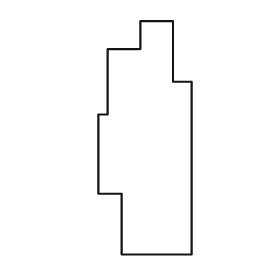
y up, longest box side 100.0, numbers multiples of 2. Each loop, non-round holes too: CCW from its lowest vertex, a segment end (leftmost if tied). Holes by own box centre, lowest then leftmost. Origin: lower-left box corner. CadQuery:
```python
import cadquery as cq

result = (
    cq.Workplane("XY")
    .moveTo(10.0, 0.0)
    .lineTo(40.0, 0.0)
    .lineTo(40.0, 74.0)
    .lineTo(32.0, 74.0)
    .lineTo(32.0, 100.0)
    .lineTo(18.0, 100.0)
    .lineTo(18.0, 88.0)
    .lineTo(4.0, 88.0)
    .lineTo(4.0, 60.0)
    .lineTo(0.0, 60.0)
    .lineTo(0.0, 26.0)
    .lineTo(10.0, 26.0)
    .close()
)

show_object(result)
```